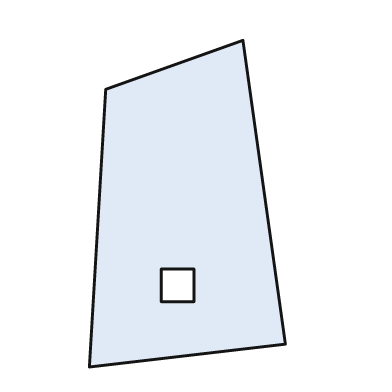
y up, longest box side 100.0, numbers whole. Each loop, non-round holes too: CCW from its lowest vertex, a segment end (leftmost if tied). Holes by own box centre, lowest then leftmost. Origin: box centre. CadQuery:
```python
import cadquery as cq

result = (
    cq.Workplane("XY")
    .moveTo(-30.0, -50.0)
    .lineTo(30.0, -43.0)
    .lineTo(17.0, 50.0)
    .lineTo(-25.0, 35.0)
    .close()
    .moveTo(-8.0, -30.0)
    .lineTo(2.0, -30.0)
    .lineTo(2.0, -20.0)
    .lineTo(-8.0, -20.0)
    .close()
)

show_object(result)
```